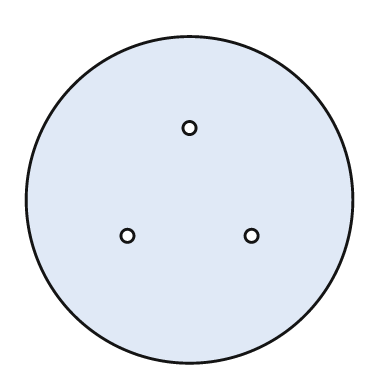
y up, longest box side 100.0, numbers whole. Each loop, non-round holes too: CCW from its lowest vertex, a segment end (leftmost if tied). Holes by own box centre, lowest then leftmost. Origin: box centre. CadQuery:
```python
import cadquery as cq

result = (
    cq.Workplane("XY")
    .moveTo(0.0, 0.0)
    .circle(50.0)
    .moveTo(-19.0, -11.0)
    .circle(2.0)
    .moveTo(19.0, -11.0)
    .circle(2.0)
    .moveTo(0.0, 22.0)
    .circle(2.0)
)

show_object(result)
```